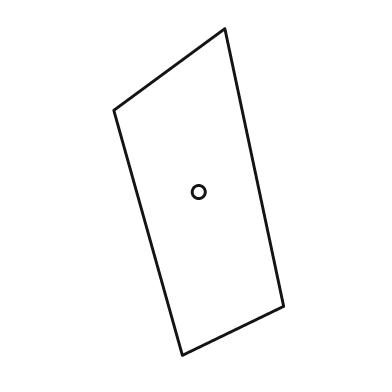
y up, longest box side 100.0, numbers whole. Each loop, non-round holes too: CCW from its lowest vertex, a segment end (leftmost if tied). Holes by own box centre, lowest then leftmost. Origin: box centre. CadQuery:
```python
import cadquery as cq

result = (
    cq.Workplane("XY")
    .moveTo(-5.0, -50.0)
    .lineTo(26.0, -35.0)
    .lineTo(8.0, 50.0)
    .lineTo(-26.0, 25.0)
    .close()
    .moveTo(0.0, 0.0)
    .circle(2.0)
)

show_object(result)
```